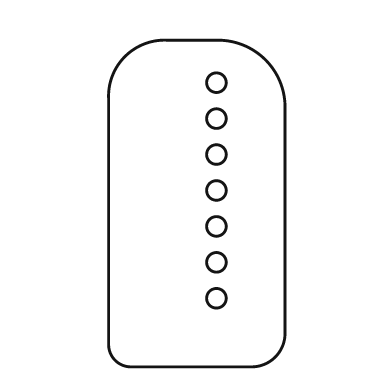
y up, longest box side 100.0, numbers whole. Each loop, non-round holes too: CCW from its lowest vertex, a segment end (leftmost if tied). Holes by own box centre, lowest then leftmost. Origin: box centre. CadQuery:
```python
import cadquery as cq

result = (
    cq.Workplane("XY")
    .moveTo(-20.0, -50.0)
    .lineTo(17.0, -50.0)
    .threePointArc((24.0, -47.0), (27.0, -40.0))
    .lineTo(27.0, 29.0)
    .threePointArc((21.0, 44.0), (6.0, 50.0))
    .lineTo(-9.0, 50.0)
    .threePointArc((-22.0, 45.0), (-27.0, 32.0))
    .lineTo(-27.0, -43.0)
    .threePointArc((-25.0, -48.0), (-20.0, -50.0))
    .close()
    .moveTo(6.0, -29.0)
    .circle(3.0)
    .moveTo(6.0, -18.0)
    .circle(3.0)
    .moveTo(6.0, -7.0)
    .circle(3.0)
    .moveTo(6.0, 4.0)
    .circle(3.0)
    .moveTo(6.0, 15.0)
    .circle(3.0)
    .moveTo(6.0, 26.0)
    .circle(3.0)
    .moveTo(6.0, 37.0)
    .circle(3.0)
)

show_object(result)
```